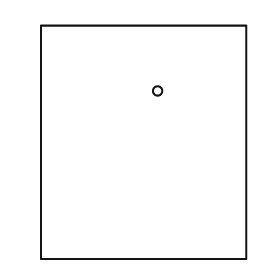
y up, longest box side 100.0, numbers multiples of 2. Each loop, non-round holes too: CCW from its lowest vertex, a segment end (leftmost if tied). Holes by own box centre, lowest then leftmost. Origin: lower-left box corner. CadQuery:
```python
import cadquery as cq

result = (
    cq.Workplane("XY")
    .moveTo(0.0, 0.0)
    .lineTo(88.0, 0.0)
    .lineTo(88.0, 100.0)
    .lineTo(0.0, 100.0)
    .close()
    .moveTo(50.0, 72.0)
    .circle(2.0)
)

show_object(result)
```